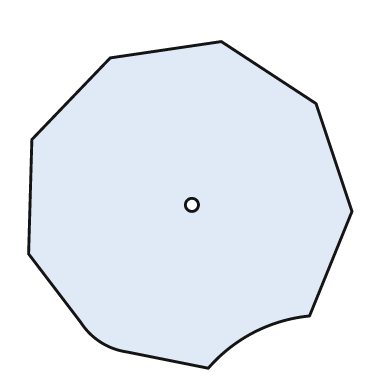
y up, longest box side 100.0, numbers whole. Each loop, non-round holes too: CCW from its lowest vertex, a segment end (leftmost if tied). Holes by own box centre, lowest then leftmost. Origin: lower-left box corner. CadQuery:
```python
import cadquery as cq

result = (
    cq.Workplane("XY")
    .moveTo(55.0, 0.0)
    .threePointArc((69.0, 11.0), (86.0, 16.0))
    .lineTo(99.0, 48.0)
    .lineTo(88.0, 81.0)
    .lineTo(59.0, 100.0)
    .lineTo(25.0, 95.0)
    .lineTo(1.0, 70.0)
    .lineTo(0.0, 35.0)
    .lineTo(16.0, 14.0)
    .threePointArc((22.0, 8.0), (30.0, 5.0))
    .close()
    .moveTo(50.0, 50.0)
    .circle(2.0)
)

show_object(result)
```